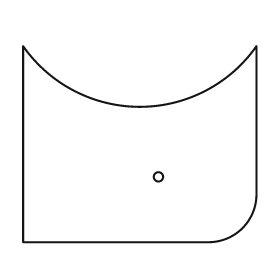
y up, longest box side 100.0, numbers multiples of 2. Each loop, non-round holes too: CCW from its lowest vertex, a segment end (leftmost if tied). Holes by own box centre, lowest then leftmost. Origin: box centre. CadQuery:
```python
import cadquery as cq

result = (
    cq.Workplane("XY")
    .moveTo(-50.0, -42.0)
    .lineTo(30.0, -42.0)
    .threePointArc((44.0, -36.0), (50.0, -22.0))
    .lineTo(50.0, 42.0)
    .threePointArc((0.0, 16.0), (-50.0, 42.0))
    .close()
    .moveTo(8.0, -14.0)
    .circle(2.0)
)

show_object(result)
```